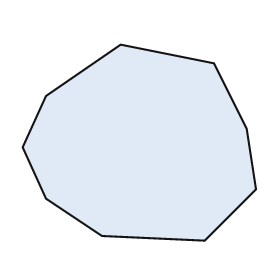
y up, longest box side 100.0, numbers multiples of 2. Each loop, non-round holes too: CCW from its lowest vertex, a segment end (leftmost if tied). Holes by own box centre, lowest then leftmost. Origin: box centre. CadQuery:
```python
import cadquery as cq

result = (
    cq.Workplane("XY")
    .moveTo(28.0, -42.0)
    .lineTo(50.0, -20.0)
    .lineTo(46.0, 6.0)
    .lineTo(32.0, 34.0)
    .lineTo(-8.0, 42.0)
    .lineTo(-40.0, 20.0)
    .lineTo(-50.0, -2.0)
    .lineTo(-40.0, -24.0)
    .lineTo(-16.0, -40.0)
    .close()
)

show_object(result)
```